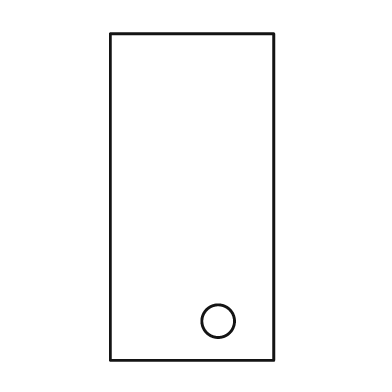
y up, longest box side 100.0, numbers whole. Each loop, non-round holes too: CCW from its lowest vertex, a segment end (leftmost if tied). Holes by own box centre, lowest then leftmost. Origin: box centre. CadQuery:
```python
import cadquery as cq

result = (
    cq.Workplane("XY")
    .moveTo(-25.0, -50.0)
    .lineTo(25.0, -50.0)
    .lineTo(25.0, 50.0)
    .lineTo(-25.0, 50.0)
    .close()
    .moveTo(8.0, -38.0)
    .circle(5.0)
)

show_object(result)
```